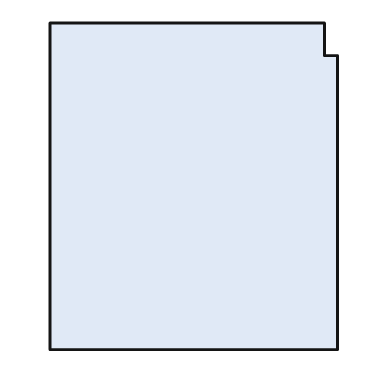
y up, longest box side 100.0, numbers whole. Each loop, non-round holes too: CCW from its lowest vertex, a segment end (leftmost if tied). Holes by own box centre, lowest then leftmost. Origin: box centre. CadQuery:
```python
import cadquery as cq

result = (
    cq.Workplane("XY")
    .moveTo(-44.0, -50.0)
    .lineTo(44.0, -50.0)
    .lineTo(44.0, 40.0)
    .lineTo(40.0, 40.0)
    .lineTo(40.0, 50.0)
    .lineTo(-44.0, 50.0)
    .close()
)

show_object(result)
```